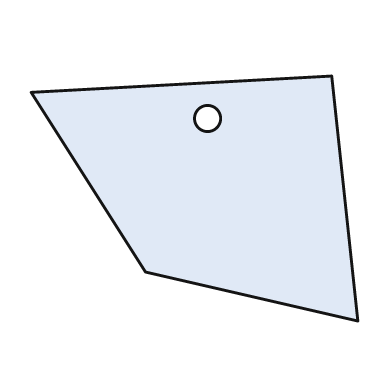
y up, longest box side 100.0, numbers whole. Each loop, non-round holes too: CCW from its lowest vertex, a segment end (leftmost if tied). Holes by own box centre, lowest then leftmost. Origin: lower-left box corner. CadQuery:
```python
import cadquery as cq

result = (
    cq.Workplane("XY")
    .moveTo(100.0, 0.0)
    .lineTo(92.0, 75.0)
    .lineTo(0.0, 70.0)
    .lineTo(35.0, 15.0)
    .close()
    .moveTo(54.0, 62.0)
    .circle(4.0)
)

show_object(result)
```